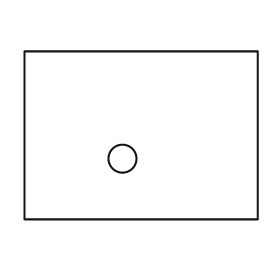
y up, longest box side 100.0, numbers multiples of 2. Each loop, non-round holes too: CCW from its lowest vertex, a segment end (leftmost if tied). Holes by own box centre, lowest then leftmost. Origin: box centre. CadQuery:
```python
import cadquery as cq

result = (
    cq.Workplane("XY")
    .moveTo(-50.0, -36.0)
    .lineTo(50.0, -36.0)
    .lineTo(50.0, 36.0)
    .lineTo(-50.0, 36.0)
    .close()
    .moveTo(-8.0, -10.0)
    .circle(6.0)
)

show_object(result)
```